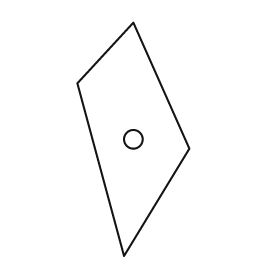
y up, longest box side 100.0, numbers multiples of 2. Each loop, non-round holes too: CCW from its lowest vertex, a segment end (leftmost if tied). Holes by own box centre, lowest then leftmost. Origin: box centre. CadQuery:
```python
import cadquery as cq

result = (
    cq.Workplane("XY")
    .moveTo(-4.0, -50.0)
    .lineTo(24.0, -4.0)
    .lineTo(0.0, 50.0)
    .lineTo(-24.0, 24.0)
    .close()
    .moveTo(0.0, 0.0)
    .circle(4.0)
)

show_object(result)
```